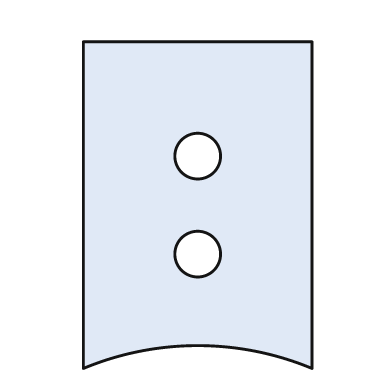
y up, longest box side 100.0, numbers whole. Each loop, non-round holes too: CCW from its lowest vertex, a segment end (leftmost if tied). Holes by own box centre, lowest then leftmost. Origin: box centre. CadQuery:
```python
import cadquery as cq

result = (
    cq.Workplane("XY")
    .moveTo(-35.0, -50.0)
    .threePointArc((0.0, -43.0), (35.0, -50.0))
    .lineTo(35.0, 50.0)
    .lineTo(-35.0, 50.0)
    .close()
    .moveTo(0.0, -15.0)
    .circle(7.0)
    .moveTo(0.0, 15.0)
    .circle(7.0)
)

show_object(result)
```